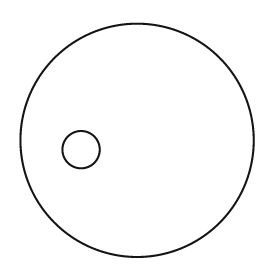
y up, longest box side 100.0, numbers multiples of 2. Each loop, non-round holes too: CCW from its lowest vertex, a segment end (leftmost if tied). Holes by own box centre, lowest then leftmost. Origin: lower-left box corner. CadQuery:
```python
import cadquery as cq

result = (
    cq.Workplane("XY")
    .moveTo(50.0, 50.0)
    .circle(50.0)
    .moveTo(26.0, 46.0)
    .circle(8.0)
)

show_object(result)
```